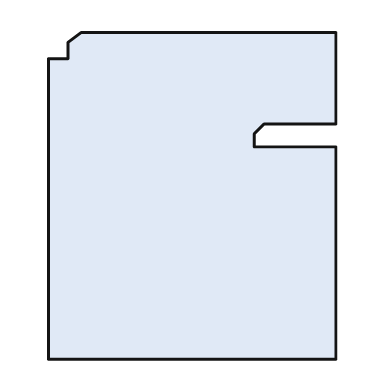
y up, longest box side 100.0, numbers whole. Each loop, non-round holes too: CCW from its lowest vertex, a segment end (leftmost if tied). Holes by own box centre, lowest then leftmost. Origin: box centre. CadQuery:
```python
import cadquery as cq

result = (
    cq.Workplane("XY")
    .moveTo(-44.0, -50.0)
    .lineTo(44.0, -50.0)
    .lineTo(44.0, 15.0)
    .lineTo(19.0, 15.0)
    .lineTo(19.0, 19.0)
    .lineTo(22.0, 22.0)
    .lineTo(44.0, 22.0)
    .lineTo(44.0, 50.0)
    .lineTo(-34.0, 50.0)
    .lineTo(-38.0, 47.0)
    .lineTo(-38.0, 42.0)
    .lineTo(-44.0, 42.0)
    .close()
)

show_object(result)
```